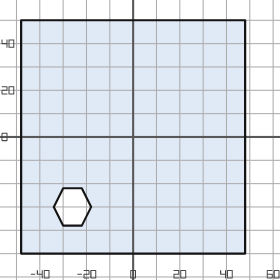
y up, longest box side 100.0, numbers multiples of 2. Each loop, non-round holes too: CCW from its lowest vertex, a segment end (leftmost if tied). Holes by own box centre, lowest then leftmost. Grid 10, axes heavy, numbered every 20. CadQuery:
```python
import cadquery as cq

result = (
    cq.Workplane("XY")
    .moveTo(-48.0, -50.0)
    .lineTo(48.0, -50.0)
    .lineTo(48.0, 50.0)
    .lineTo(-48.0, 50.0)
    .close()
    .moveTo(-30.0, -38.0)
    .lineTo(-22.0, -38.0)
    .lineTo(-18.0, -30.0)
    .lineTo(-22.0, -22.0)
    .lineTo(-30.0, -22.0)
    .lineTo(-34.0, -30.0)
    .close()
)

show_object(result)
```